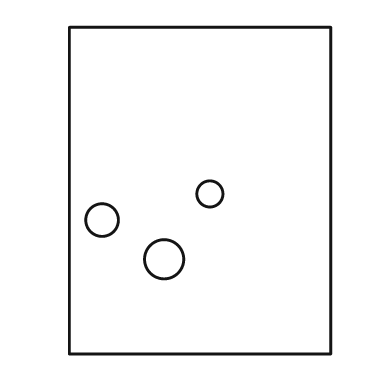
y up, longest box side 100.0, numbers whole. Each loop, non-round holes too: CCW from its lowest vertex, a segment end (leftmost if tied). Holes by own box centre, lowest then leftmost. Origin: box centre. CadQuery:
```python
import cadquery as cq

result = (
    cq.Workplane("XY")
    .moveTo(-40.0, -50.0)
    .lineTo(40.0, -50.0)
    .lineTo(40.0, 50.0)
    .lineTo(-40.0, 50.0)
    .close()
    .moveTo(-11.0, -21.0)
    .circle(6.0)
    .moveTo(-30.0, -9.0)
    .circle(5.0)
    .moveTo(3.0, -1.0)
    .circle(4.0)
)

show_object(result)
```